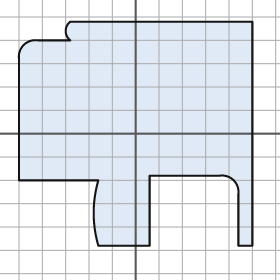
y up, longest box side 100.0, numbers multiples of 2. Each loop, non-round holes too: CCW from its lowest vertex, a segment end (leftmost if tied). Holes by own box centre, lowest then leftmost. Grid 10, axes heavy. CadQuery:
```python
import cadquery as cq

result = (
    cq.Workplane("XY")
    .moveTo(-16.0, -48.0)
    .lineTo(6.0, -48.0)
    .lineTo(6.0, -18.0)
    .lineTo(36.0, -18.0)
    .threePointArc((42.0, -20.0), (44.0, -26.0))
    .lineTo(44.0, -48.0)
    .lineTo(50.0, -48.0)
    .lineTo(50.0, 48.0)
    .lineTo(-28.0, 48.0)
    .threePointArc((-30.0, 44.0), (-28.0, 40.0))
    .lineTo(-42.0, 40.0)
    .threePointArc((-48.0, 38.0), (-50.0, 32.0))
    .lineTo(-50.0, -20.0)
    .lineTo(-16.0, -20.0)
    .threePointArc((-18.0, -34.0), (-16.0, -48.0))
    .close()
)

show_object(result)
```